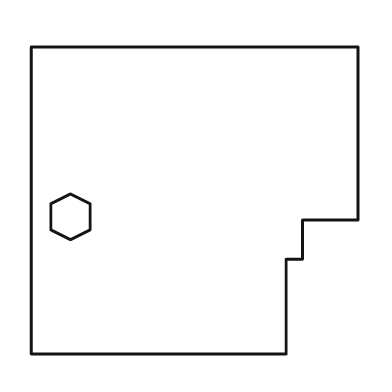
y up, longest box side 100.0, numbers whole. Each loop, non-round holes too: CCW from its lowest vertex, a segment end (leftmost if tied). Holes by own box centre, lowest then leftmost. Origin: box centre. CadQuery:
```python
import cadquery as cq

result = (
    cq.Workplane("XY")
    .moveTo(-50.0, -47.0)
    .lineTo(28.0, -47.0)
    .lineTo(28.0, -18.0)
    .lineTo(33.0, -18.0)
    .lineTo(33.0, -6.0)
    .lineTo(50.0, -6.0)
    .lineTo(50.0, 47.0)
    .lineTo(-50.0, 47.0)
    .close()
    .moveTo(-38.0, -12.0)
    .lineTo(-32.0, -9.0)
    .lineTo(-32.0, -1.0)
    .lineTo(-38.0, 2.0)
    .lineTo(-44.0, -1.0)
    .lineTo(-44.0, -9.0)
    .close()
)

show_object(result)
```